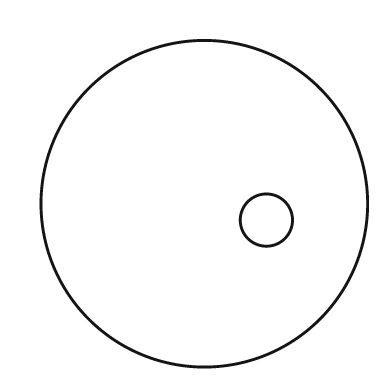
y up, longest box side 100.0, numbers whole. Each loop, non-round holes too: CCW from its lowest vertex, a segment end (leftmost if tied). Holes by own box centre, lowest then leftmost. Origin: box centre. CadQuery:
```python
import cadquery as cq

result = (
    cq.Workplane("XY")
    .moveTo(0.0, 0.0)
    .circle(50.0)
    .moveTo(19.0, -5.0)
    .circle(8.0)
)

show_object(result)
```